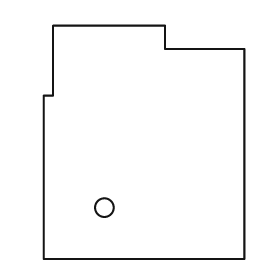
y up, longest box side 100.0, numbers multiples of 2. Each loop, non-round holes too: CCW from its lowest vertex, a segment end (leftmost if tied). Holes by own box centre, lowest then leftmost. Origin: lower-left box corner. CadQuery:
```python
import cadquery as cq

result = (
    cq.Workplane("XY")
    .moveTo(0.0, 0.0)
    .lineTo(86.0, 0.0)
    .lineTo(86.0, 90.0)
    .lineTo(52.0, 90.0)
    .lineTo(52.0, 100.0)
    .lineTo(4.0, 100.0)
    .lineTo(4.0, 70.0)
    .lineTo(0.0, 70.0)
    .close()
    .moveTo(26.0, 22.0)
    .circle(4.0)
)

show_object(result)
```